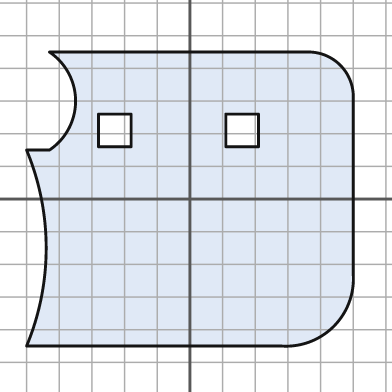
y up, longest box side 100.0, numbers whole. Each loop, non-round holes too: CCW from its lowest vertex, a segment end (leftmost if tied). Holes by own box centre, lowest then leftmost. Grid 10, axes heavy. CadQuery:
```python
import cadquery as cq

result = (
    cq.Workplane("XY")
    .moveTo(-50.0, -45.0)
    .lineTo(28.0, -45.0)
    .threePointArc((44.0, -39.0), (50.0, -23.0))
    .lineTo(50.0, 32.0)
    .threePointArc((46.0, 41.0), (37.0, 45.0))
    .lineTo(-43.0, 45.0)
    .threePointArc((-35.0, 30.0), (-43.0, 15.0))
    .lineTo(-50.0, 15.0)
    .threePointArc((-44.0, -15.0), (-50.0, -45.0))
    .close()
    .moveTo(-28.0, 16.0)
    .lineTo(-18.0, 16.0)
    .lineTo(-18.0, 26.0)
    .lineTo(-28.0, 26.0)
    .close()
    .moveTo(11.0, 16.0)
    .lineTo(21.0, 16.0)
    .lineTo(21.0, 26.0)
    .lineTo(11.0, 26.0)
    .close()
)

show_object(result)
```